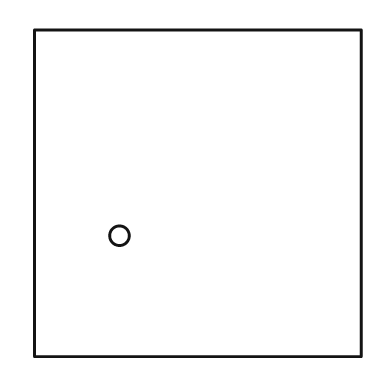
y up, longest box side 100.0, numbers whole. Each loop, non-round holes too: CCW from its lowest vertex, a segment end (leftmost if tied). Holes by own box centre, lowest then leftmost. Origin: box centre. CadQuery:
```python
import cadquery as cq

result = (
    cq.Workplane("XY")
    .moveTo(-50.0, -50.0)
    .lineTo(50.0, -50.0)
    .lineTo(50.0, 50.0)
    .lineTo(-50.0, 50.0)
    .close()
    .moveTo(-24.0, -13.0)
    .circle(3.0)
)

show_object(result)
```